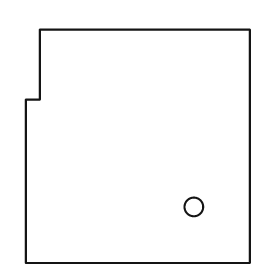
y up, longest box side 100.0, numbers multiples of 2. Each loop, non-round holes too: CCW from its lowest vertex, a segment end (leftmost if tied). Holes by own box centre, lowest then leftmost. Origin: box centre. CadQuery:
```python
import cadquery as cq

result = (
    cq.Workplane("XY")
    .moveTo(-48.0, -50.0)
    .lineTo(48.0, -50.0)
    .lineTo(48.0, 50.0)
    .lineTo(-42.0, 50.0)
    .lineTo(-42.0, 20.0)
    .lineTo(-48.0, 20.0)
    .close()
    .moveTo(24.0, -26.0)
    .circle(4.0)
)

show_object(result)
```